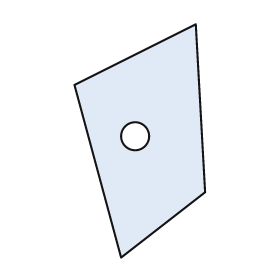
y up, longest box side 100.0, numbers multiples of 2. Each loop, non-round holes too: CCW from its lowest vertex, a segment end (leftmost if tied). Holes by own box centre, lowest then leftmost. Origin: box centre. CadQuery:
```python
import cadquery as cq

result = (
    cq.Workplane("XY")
    .moveTo(-8.0, -50.0)
    .lineTo(28.0, -22.0)
    .lineTo(24.0, 50.0)
    .lineTo(-28.0, 24.0)
    .close()
    .moveTo(-2.0, 2.0)
    .circle(6.0)
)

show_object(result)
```